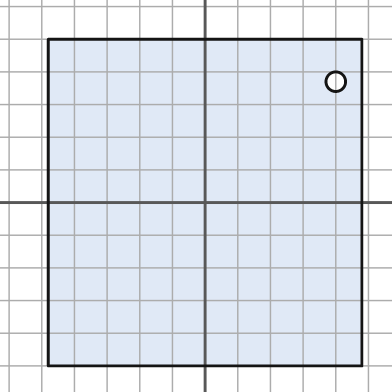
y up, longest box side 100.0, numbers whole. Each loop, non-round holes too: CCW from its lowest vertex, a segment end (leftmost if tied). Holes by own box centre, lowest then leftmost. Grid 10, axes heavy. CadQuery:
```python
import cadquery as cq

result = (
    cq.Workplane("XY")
    .moveTo(-48.0, -50.0)
    .lineTo(48.0, -50.0)
    .lineTo(48.0, 50.0)
    .lineTo(-48.0, 50.0)
    .close()
    .moveTo(40.0, 37.0)
    .circle(3.0)
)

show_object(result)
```